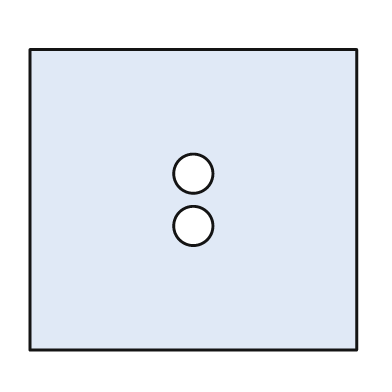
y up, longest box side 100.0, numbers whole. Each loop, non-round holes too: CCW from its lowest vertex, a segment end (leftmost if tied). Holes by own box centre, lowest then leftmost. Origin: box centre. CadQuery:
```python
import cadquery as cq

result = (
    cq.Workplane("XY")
    .moveTo(-50.0, -46.0)
    .lineTo(50.0, -46.0)
    .lineTo(50.0, 46.0)
    .lineTo(-50.0, 46.0)
    .close()
    .moveTo(0.0, -8.0)
    .circle(6.0)
    .moveTo(0.0, 8.0)
    .circle(6.0)
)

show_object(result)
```